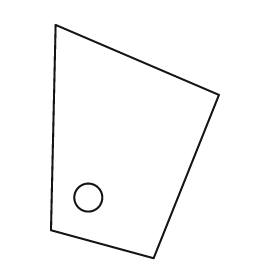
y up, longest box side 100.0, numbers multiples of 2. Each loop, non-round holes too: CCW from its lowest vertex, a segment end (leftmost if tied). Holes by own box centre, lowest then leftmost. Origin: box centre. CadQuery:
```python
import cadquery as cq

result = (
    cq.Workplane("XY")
    .moveTo(8.0, -50.0)
    .lineTo(36.0, 20.0)
    .lineTo(-34.0, 50.0)
    .lineTo(-36.0, -38.0)
    .close()
    .moveTo(-20.0, -24.0)
    .circle(6.0)
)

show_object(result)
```